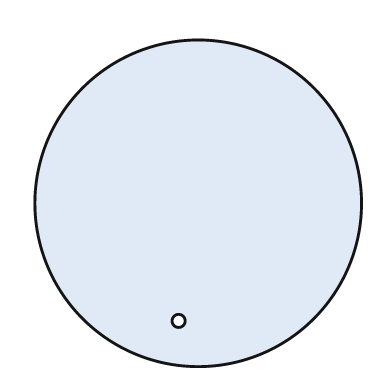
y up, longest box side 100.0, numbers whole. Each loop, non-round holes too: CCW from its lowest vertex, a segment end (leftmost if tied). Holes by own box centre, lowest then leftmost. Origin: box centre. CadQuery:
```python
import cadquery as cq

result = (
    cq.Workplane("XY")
    .moveTo(0.0, 0.0)
    .circle(50.0)
    .moveTo(-6.0, -36.0)
    .circle(2.0)
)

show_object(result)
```